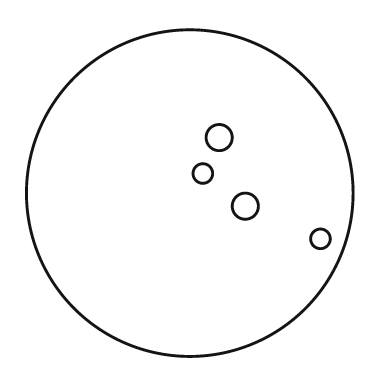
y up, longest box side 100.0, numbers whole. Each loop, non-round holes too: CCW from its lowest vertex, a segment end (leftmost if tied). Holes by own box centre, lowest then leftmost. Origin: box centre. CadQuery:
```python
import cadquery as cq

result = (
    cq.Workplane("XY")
    .moveTo(0.0, 0.0)
    .circle(50.0)
    .moveTo(40.0, -14.0)
    .circle(3.0)
    .moveTo(17.0, -4.0)
    .circle(4.0)
    .moveTo(4.0, 6.0)
    .circle(3.0)
    .moveTo(9.0, 17.0)
    .circle(4.0)
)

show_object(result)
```